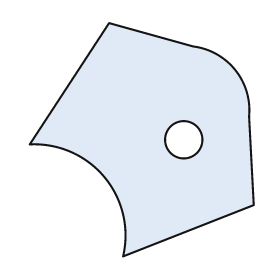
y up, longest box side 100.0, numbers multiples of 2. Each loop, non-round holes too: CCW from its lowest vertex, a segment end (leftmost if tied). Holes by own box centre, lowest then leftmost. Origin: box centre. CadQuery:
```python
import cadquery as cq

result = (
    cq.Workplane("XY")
    .moveTo(-8.0, -50.0)
    .lineTo(48.0, -28.0)
    .lineTo(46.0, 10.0)
    .threePointArc((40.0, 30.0), (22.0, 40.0))
    .lineTo(-14.0, 50.0)
    .lineTo(-48.0, -2.0)
    .threePointArc((-16.0, -16.0), (-8.0, -50.0))
    .close()
    .moveTo(18.0, 0.0)
    .circle(8.0)
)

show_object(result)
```